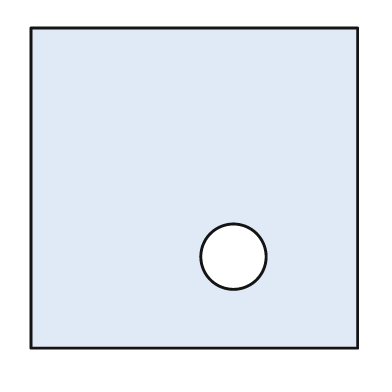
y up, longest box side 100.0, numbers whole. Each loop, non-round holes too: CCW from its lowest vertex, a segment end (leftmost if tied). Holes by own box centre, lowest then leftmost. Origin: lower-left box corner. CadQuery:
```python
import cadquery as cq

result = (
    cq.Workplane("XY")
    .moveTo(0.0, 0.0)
    .lineTo(100.0, 0.0)
    .lineTo(100.0, 98.0)
    .lineTo(0.0, 98.0)
    .close()
    .moveTo(62.0, 28.0)
    .circle(10.0)
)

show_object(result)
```